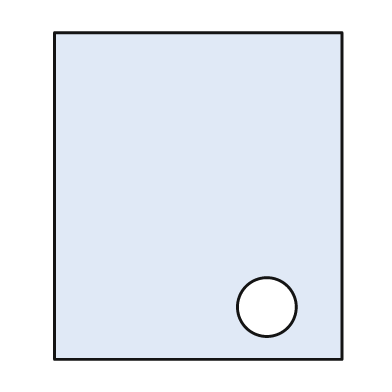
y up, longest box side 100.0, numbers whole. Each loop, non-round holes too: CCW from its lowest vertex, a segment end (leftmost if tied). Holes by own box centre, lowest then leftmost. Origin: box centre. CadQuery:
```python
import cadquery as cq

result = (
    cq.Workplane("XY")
    .moveTo(-44.0, -50.0)
    .lineTo(44.0, -50.0)
    .lineTo(44.0, 50.0)
    .lineTo(-44.0, 50.0)
    .close()
    .moveTo(21.0, -34.0)
    .circle(9.0)
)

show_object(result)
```